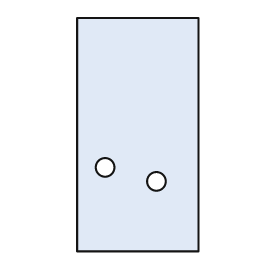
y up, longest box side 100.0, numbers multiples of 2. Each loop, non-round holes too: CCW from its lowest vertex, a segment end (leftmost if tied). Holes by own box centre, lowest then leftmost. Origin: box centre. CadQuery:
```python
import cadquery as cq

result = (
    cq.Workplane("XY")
    .moveTo(-26.0, -50.0)
    .lineTo(26.0, -50.0)
    .lineTo(26.0, 50.0)
    .lineTo(-26.0, 50.0)
    .close()
    .moveTo(8.0, -20.0)
    .circle(4.0)
    .moveTo(-14.0, -14.0)
    .circle(4.0)
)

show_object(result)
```